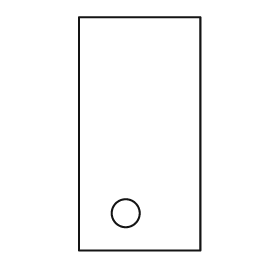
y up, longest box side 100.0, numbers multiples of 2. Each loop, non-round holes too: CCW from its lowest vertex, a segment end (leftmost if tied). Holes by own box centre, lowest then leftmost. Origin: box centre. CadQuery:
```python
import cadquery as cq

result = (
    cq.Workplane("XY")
    .moveTo(-26.0, -50.0)
    .lineTo(26.0, -50.0)
    .lineTo(26.0, 50.0)
    .lineTo(-26.0, 50.0)
    .close()
    .moveTo(-6.0, -34.0)
    .circle(6.0)
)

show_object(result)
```